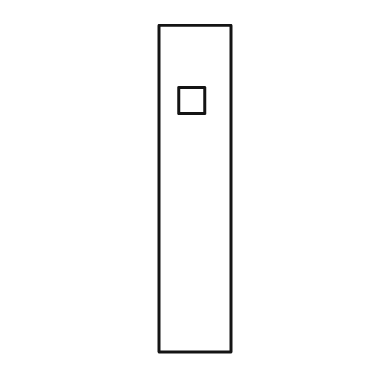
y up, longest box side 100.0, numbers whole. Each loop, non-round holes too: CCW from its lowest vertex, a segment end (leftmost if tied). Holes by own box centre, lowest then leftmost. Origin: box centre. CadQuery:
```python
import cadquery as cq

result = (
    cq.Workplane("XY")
    .moveTo(-11.0, -50.0)
    .lineTo(11.0, -50.0)
    .lineTo(11.0, 50.0)
    .lineTo(-11.0, 50.0)
    .close()
    .moveTo(-5.0, 23.0)
    .lineTo(3.0, 23.0)
    .lineTo(3.0, 31.0)
    .lineTo(-5.0, 31.0)
    .close()
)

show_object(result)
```